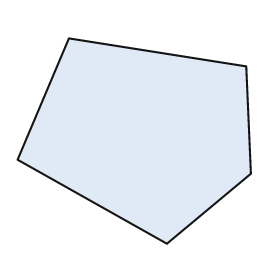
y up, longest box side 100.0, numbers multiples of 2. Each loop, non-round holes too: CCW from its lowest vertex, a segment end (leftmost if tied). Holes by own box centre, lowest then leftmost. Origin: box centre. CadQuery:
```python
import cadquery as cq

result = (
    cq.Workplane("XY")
    .moveTo(14.0, -44.0)
    .lineTo(50.0, -14.0)
    .lineTo(48.0, 32.0)
    .lineTo(-28.0, 44.0)
    .lineTo(-50.0, -8.0)
    .close()
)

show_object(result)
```